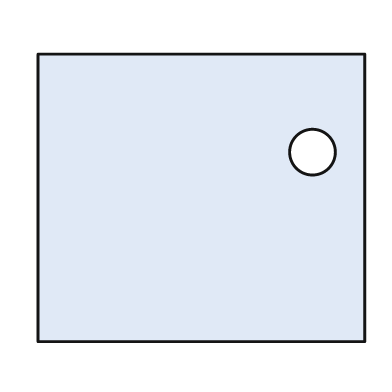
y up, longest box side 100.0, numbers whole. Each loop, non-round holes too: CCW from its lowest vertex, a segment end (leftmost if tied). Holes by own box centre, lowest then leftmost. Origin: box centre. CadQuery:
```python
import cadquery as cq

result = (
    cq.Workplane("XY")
    .moveTo(-50.0, -44.0)
    .lineTo(50.0, -44.0)
    .lineTo(50.0, 44.0)
    .lineTo(-50.0, 44.0)
    .close()
    .moveTo(34.0, 14.0)
    .circle(7.0)
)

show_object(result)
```